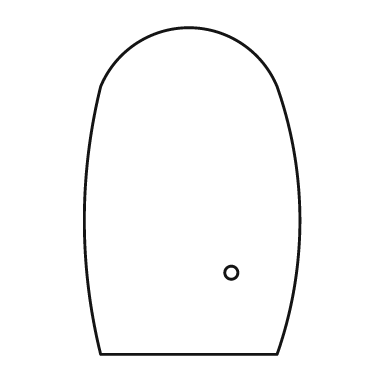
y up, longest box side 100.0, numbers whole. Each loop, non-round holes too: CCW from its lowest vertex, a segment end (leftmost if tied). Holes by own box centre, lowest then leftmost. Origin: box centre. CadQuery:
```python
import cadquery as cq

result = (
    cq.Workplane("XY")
    .moveTo(-28.0, -50.0)
    .lineTo(26.0, -50.0)
    .threePointArc((33.0, -9.0), (26.0, 32.0))
    .threePointArc((-1.0, 50.0), (-28.0, 32.0))
    .threePointArc((-33.0, -9.0), (-28.0, -50.0))
    .close()
    .moveTo(12.0, -25.0)
    .circle(2.0)
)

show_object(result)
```